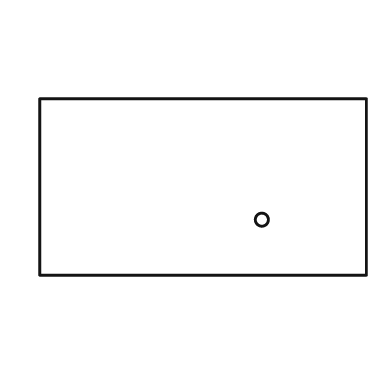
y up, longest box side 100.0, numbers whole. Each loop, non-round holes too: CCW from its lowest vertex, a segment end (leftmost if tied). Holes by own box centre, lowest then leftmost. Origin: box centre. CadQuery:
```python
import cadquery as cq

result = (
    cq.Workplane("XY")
    .moveTo(-50.0, -27.0)
    .lineTo(50.0, -27.0)
    .lineTo(50.0, 27.0)
    .lineTo(-50.0, 27.0)
    .close()
    .moveTo(18.0, -10.0)
    .circle(2.0)
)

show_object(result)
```